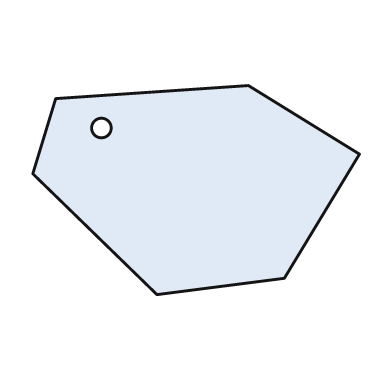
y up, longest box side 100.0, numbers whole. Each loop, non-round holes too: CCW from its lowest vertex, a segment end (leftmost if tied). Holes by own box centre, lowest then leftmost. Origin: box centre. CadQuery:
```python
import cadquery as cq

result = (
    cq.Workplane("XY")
    .moveTo(-12.0, -32.0)
    .lineTo(27.0, -27.0)
    .lineTo(50.0, 11.0)
    .lineTo(16.0, 32.0)
    .lineTo(-43.0, 28.0)
    .lineTo(-50.0, 5.0)
    .close()
    .moveTo(-29.0, 19.0)
    .circle(3.0)
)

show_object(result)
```